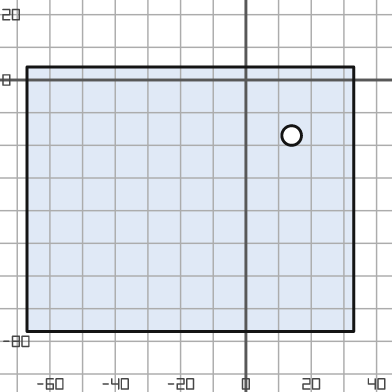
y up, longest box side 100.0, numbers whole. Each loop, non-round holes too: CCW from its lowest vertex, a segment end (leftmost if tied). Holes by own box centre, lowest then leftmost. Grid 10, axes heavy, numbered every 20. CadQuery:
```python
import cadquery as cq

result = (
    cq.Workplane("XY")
    .moveTo(-67.0, -77.0)
    .lineTo(33.0, -77.0)
    .lineTo(33.0, 4.0)
    .lineTo(-67.0, 4.0)
    .close()
    .moveTo(14.0, -17.0)
    .circle(3.0)
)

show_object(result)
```